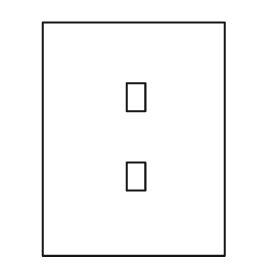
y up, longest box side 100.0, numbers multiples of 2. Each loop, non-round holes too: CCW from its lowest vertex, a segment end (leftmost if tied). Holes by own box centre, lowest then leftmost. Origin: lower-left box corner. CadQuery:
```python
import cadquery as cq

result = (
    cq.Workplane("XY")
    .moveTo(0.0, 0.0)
    .lineTo(78.0, 0.0)
    .lineTo(78.0, 100.0)
    .lineTo(0.0, 100.0)
    .close()
    .moveTo(36.0, 28.0)
    .lineTo(44.0, 28.0)
    .lineTo(44.0, 40.0)
    .lineTo(36.0, 40.0)
    .close()
    .moveTo(36.0, 62.0)
    .lineTo(44.0, 62.0)
    .lineTo(44.0, 74.0)
    .lineTo(36.0, 74.0)
    .close()
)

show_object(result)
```